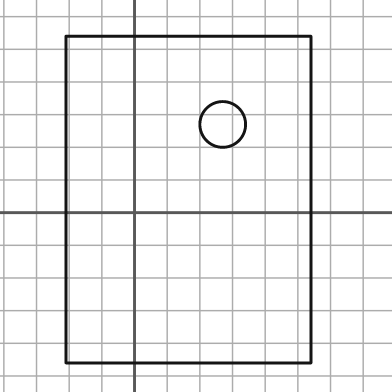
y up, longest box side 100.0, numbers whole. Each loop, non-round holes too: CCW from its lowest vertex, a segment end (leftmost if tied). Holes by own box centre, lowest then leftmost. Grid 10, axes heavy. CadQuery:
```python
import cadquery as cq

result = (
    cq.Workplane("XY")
    .moveTo(-21.0, -46.0)
    .lineTo(54.0, -46.0)
    .lineTo(54.0, 54.0)
    .lineTo(-21.0, 54.0)
    .close()
    .moveTo(27.0, 27.0)
    .circle(7.0)
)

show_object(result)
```